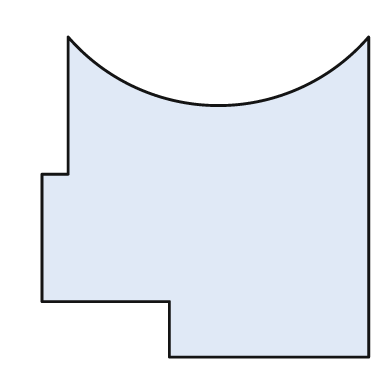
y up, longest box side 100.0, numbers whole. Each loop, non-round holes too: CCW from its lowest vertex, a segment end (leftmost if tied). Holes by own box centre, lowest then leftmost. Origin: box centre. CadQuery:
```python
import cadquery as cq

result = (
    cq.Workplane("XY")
    .moveTo(-11.0, -49.0)
    .lineTo(50.0, -49.0)
    .lineTo(50.0, 49.0)
    .threePointArc((4.0, 28.0), (-42.0, 49.0))
    .lineTo(-42.0, 7.0)
    .lineTo(-50.0, 7.0)
    .lineTo(-50.0, -32.0)
    .lineTo(-11.0, -32.0)
    .close()
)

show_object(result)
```